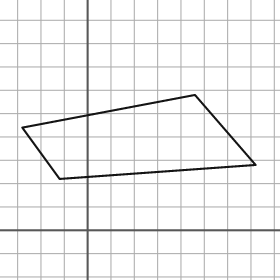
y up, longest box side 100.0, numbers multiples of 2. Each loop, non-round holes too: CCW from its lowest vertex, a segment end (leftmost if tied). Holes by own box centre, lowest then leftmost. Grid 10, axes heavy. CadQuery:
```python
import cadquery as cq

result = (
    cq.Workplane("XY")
    .moveTo(-12.0, 22.0)
    .lineTo(72.0, 28.0)
    .lineTo(46.0, 58.0)
    .lineTo(-28.0, 44.0)
    .close()
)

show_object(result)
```